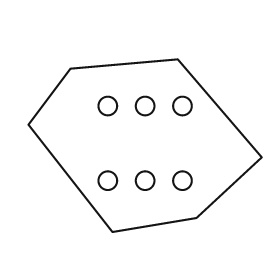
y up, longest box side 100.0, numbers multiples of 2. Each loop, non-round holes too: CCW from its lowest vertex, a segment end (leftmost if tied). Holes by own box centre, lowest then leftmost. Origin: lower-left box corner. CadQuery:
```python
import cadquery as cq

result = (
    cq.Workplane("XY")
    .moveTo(36.0, 0.0)
    .lineTo(72.0, 6.0)
    .lineTo(100.0, 32.0)
    .lineTo(64.0, 74.0)
    .lineTo(18.0, 70.0)
    .lineTo(0.0, 46.0)
    .close()
    .moveTo(34.0, 22.0)
    .circle(4.0)
    .moveTo(50.0, 22.0)
    .circle(4.0)
    .moveTo(66.0, 22.0)
    .circle(4.0)
    .moveTo(34.0, 54.0)
    .circle(4.0)
    .moveTo(50.0, 54.0)
    .circle(4.0)
    .moveTo(66.0, 54.0)
    .circle(4.0)
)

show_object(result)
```